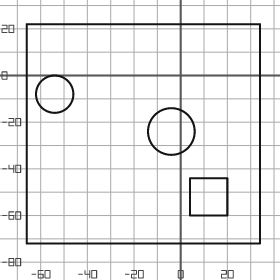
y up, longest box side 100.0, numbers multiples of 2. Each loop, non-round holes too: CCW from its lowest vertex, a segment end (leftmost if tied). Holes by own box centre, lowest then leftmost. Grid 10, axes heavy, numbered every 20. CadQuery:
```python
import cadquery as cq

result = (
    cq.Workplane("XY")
    .moveTo(-66.0, -72.0)
    .lineTo(34.0, -72.0)
    .lineTo(34.0, 22.0)
    .lineTo(-66.0, 22.0)
    .close()
    .moveTo(4.0, -60.0)
    .lineTo(20.0, -60.0)
    .lineTo(20.0, -44.0)
    .lineTo(4.0, -44.0)
    .close()
    .moveTo(-4.0, -24.0)
    .circle(10.0)
    .moveTo(-54.0, -8.0)
    .circle(8.0)
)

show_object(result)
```